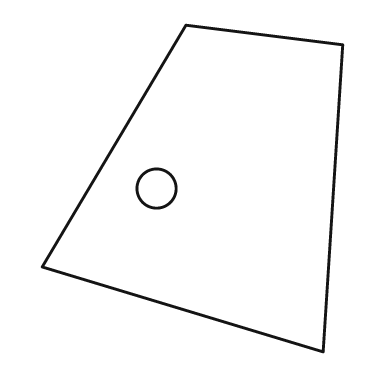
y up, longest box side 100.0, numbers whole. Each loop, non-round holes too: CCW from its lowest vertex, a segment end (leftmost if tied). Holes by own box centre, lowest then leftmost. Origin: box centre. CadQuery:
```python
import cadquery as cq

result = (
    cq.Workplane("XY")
    .moveTo(40.0, -50.0)
    .lineTo(46.0, 44.0)
    .lineTo(-2.0, 50.0)
    .lineTo(-46.0, -24.0)
    .close()
    .moveTo(-11.0, 0.0)
    .circle(6.0)
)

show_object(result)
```